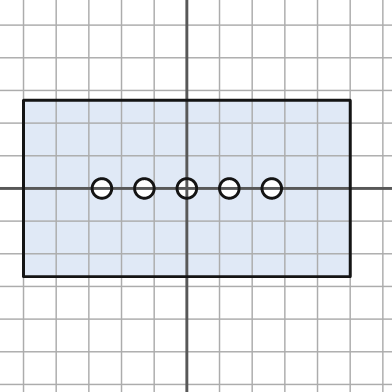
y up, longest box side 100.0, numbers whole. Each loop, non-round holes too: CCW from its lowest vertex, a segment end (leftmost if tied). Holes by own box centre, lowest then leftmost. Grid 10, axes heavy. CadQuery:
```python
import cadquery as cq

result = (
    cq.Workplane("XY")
    .moveTo(-50.0, -27.0)
    .lineTo(50.0, -27.0)
    .lineTo(50.0, 27.0)
    .lineTo(-50.0, 27.0)
    .close()
    .moveTo(-26.0, 0.0)
    .circle(3.0)
    .moveTo(-13.0, 0.0)
    .circle(3.0)
    .moveTo(0.0, 0.0)
    .circle(3.0)
    .moveTo(13.0, 0.0)
    .circle(3.0)
    .moveTo(26.0, 0.0)
    .circle(3.0)
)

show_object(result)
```